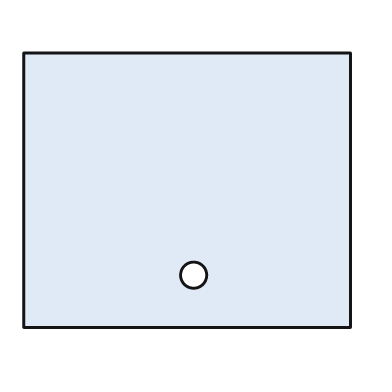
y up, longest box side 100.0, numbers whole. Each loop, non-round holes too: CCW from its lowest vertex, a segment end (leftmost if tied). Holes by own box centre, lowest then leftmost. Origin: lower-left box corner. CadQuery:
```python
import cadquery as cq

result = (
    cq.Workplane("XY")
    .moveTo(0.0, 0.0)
    .lineTo(100.0, 0.0)
    .lineTo(100.0, 84.0)
    .lineTo(0.0, 84.0)
    .close()
    .moveTo(52.0, 16.0)
    .circle(4.0)
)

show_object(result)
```